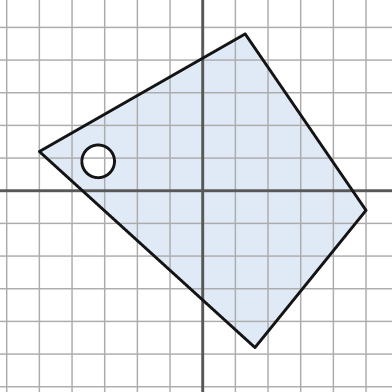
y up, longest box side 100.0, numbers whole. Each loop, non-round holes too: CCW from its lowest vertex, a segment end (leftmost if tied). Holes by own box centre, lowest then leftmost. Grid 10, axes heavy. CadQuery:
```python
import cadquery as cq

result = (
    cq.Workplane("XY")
    .moveTo(16.0, -48.0)
    .lineTo(50.0, -6.0)
    .lineTo(13.0, 48.0)
    .lineTo(-50.0, 12.0)
    .close()
    .moveTo(-32.0, 9.0)
    .circle(5.0)
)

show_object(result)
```